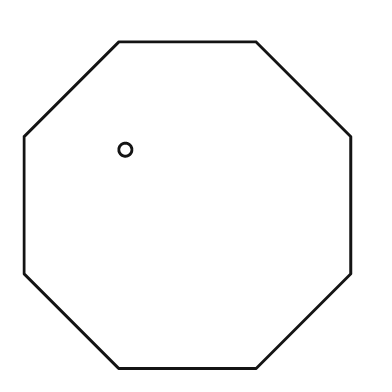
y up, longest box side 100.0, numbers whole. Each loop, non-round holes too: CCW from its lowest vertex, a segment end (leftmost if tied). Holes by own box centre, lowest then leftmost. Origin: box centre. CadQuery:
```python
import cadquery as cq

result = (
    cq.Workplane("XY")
    .moveTo(-21.0, -50.0)
    .lineTo(21.0, -50.0)
    .lineTo(50.0, -21.0)
    .lineTo(50.0, 21.0)
    .lineTo(21.0, 50.0)
    .lineTo(-21.0, 50.0)
    .lineTo(-50.0, 21.0)
    .lineTo(-50.0, -21.0)
    .close()
    .moveTo(-19.0, 17.0)
    .circle(2.0)
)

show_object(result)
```